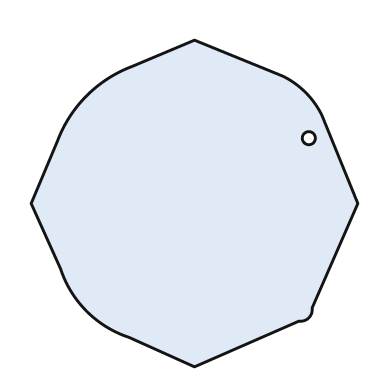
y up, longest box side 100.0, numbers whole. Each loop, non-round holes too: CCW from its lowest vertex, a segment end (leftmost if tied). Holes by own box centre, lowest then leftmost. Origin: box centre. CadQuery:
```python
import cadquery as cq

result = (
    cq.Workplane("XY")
    .moveTo(0.0, -50.0)
    .lineTo(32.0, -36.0)
    .threePointArc((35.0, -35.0), (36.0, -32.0))
    .lineTo(50.0, 0.0)
    .lineTo(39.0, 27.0)
    .threePointArc((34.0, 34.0), (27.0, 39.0))
    .lineTo(0.0, 50.0)
    .lineTo(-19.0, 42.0)
    .threePointArc((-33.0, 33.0), (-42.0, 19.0))
    .lineTo(-50.0, 0.0)
    .lineTo(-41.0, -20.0)
    .threePointArc((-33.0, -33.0), (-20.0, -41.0))
    .close()
    .moveTo(35.0, 20.0)
    .circle(2.0)
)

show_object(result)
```